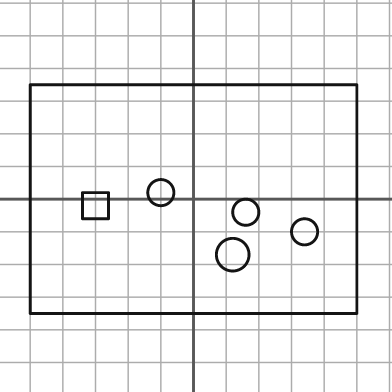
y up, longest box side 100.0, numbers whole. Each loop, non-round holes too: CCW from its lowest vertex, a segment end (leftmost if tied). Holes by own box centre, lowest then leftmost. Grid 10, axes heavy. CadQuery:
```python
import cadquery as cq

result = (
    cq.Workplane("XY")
    .moveTo(-50.0, -35.0)
    .lineTo(50.0, -35.0)
    .lineTo(50.0, 35.0)
    .lineTo(-50.0, 35.0)
    .close()
    .moveTo(12.0, -17.0)
    .circle(5.0)
    .moveTo(34.0, -10.0)
    .circle(4.0)
    .moveTo(16.0, -4.0)
    .circle(4.0)
    .moveTo(-34.0, -6.0)
    .lineTo(-26.0, -6.0)
    .lineTo(-26.0, 2.0)
    .lineTo(-34.0, 2.0)
    .close()
    .moveTo(-10.0, 2.0)
    .circle(4.0)
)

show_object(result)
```